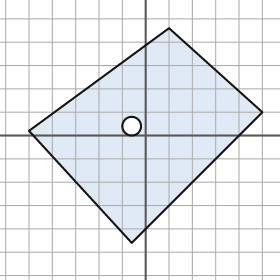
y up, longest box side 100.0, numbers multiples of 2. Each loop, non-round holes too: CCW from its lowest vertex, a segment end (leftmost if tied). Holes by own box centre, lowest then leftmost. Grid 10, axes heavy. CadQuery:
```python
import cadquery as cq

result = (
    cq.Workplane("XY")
    .moveTo(-6.0, -46.0)
    .lineTo(50.0, 10.0)
    .lineTo(10.0, 46.0)
    .lineTo(-50.0, 2.0)
    .close()
    .moveTo(-6.0, 4.0)
    .circle(4.0)
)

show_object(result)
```